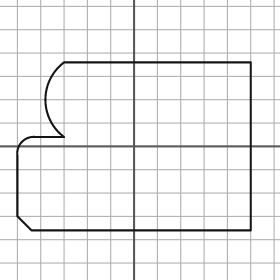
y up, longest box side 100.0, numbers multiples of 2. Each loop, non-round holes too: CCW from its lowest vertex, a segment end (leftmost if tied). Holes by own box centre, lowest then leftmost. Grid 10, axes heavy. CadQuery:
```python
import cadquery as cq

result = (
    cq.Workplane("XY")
    .moveTo(-44.0, -36.0)
    .lineTo(50.0, -36.0)
    .lineTo(50.0, 36.0)
    .lineTo(-30.0, 36.0)
    .threePointArc((-38.0, 20.0), (-30.0, 4.0))
    .lineTo(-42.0, 4.0)
    .threePointArc((-48.0, 2.0), (-50.0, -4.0))
    .lineTo(-50.0, -30.0)
    .close()
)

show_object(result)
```